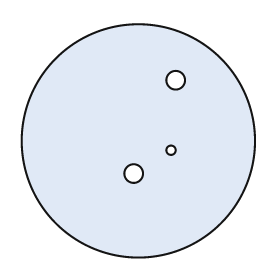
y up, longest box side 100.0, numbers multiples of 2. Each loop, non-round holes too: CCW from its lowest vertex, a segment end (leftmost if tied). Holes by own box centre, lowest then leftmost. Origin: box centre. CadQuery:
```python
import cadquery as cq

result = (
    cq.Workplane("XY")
    .moveTo(0.0, 0.0)
    .circle(50.0)
    .moveTo(-2.0, -14.0)
    .circle(4.0)
    .moveTo(14.0, -4.0)
    .circle(2.0)
    .moveTo(16.0, 26.0)
    .circle(4.0)
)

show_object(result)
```